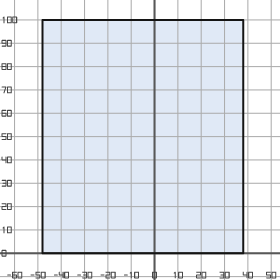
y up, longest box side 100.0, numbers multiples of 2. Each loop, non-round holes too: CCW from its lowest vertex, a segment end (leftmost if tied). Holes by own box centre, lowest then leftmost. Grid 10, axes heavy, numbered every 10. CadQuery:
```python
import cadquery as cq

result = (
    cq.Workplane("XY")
    .moveTo(-48.0, 0.0)
    .lineTo(38.0, 0.0)
    .lineTo(38.0, 100.0)
    .lineTo(-48.0, 100.0)
    .close()
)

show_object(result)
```